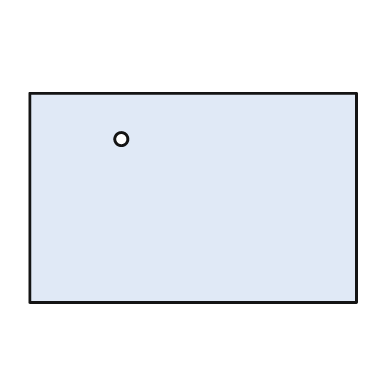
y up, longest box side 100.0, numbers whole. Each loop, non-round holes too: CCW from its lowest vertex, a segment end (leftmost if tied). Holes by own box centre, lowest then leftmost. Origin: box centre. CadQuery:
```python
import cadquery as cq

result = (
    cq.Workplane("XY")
    .moveTo(-50.0, -32.0)
    .lineTo(50.0, -32.0)
    .lineTo(50.0, 32.0)
    .lineTo(-50.0, 32.0)
    .close()
    .moveTo(-22.0, 18.0)
    .circle(2.0)
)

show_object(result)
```